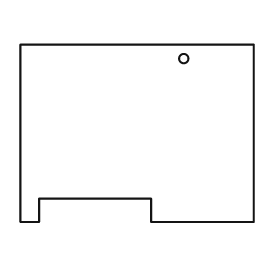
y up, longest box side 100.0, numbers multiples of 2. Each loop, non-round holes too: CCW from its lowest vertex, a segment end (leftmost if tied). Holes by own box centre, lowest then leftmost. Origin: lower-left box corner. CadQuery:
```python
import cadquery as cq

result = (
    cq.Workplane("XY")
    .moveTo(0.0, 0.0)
    .lineTo(8.0, 0.0)
    .lineTo(8.0, 10.0)
    .lineTo(56.0, 10.0)
    .lineTo(56.0, 0.0)
    .lineTo(100.0, 0.0)
    .lineTo(100.0, 76.0)
    .lineTo(0.0, 76.0)
    .close()
    .moveTo(70.0, 70.0)
    .circle(2.0)
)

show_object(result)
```